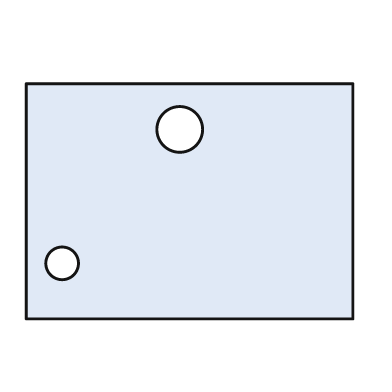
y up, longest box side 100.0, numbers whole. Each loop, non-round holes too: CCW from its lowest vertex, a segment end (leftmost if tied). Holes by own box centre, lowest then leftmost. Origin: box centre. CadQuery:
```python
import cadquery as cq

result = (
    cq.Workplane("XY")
    .moveTo(-50.0, -36.0)
    .lineTo(50.0, -36.0)
    .lineTo(50.0, 36.0)
    .lineTo(-50.0, 36.0)
    .close()
    .moveTo(-39.0, -19.0)
    .circle(5.0)
    .moveTo(-3.0, 22.0)
    .circle(7.0)
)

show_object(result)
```